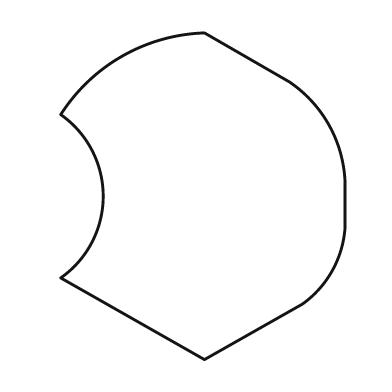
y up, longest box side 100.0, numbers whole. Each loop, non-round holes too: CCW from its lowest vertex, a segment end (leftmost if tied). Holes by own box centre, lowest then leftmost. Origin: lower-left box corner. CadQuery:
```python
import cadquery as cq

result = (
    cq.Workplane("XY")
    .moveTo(44.0, 0.0)
    .lineTo(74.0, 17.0)
    .threePointArc((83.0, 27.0), (87.0, 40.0))
    .lineTo(87.0, 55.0)
    .threePointArc((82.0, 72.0), (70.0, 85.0))
    .lineTo(44.0, 100.0)
    .threePointArc((19.0, 93.0), (0.0, 75.0))
    .threePointArc((13.0, 50.0), (0.0, 25.0))
    .close()
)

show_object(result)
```